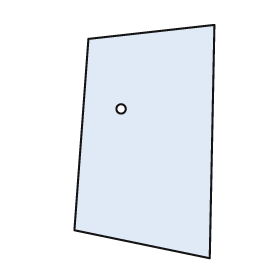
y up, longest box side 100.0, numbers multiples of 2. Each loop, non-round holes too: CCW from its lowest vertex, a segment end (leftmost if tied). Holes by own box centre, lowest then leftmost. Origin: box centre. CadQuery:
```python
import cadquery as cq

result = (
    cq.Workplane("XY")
    .moveTo(28.0, -50.0)
    .lineTo(30.0, 50.0)
    .lineTo(-24.0, 44.0)
    .lineTo(-30.0, -38.0)
    .close()
    .moveTo(-10.0, 14.0)
    .circle(2.0)
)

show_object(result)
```